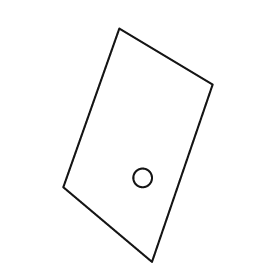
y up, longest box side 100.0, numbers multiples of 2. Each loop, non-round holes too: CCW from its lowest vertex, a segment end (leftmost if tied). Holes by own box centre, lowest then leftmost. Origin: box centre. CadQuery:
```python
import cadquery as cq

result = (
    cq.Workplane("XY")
    .moveTo(6.0, -50.0)
    .lineTo(32.0, 26.0)
    .lineTo(-8.0, 50.0)
    .lineTo(-32.0, -18.0)
    .close()
    .moveTo(2.0, -14.0)
    .circle(4.0)
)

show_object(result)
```